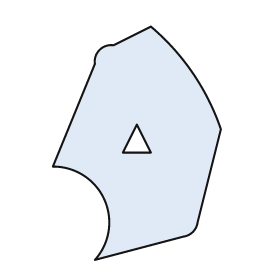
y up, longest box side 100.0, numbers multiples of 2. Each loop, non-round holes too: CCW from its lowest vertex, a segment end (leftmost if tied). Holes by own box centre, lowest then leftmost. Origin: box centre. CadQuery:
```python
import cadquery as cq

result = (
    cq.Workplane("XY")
    .moveTo(-18.0, -50.0)
    .lineTo(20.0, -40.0)
    .threePointArc((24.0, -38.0), (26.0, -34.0))
    .lineTo(36.0, 6.0)
    .threePointArc((24.0, 30.0), (6.0, 50.0))
    .lineTo(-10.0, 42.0)
    .threePointArc((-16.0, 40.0), (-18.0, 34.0))
    .lineTo(-36.0, -10.0)
    .threePointArc((-14.0, -24.0), (-18.0, -50.0))
    .close()
    .moveTo(-6.0, -4.0)
    .lineTo(6.0, -4.0)
    .lineTo(0.0, 8.0)
    .close()
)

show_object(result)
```